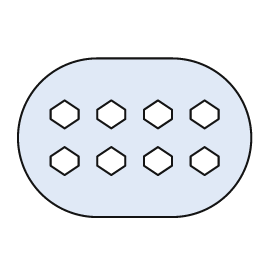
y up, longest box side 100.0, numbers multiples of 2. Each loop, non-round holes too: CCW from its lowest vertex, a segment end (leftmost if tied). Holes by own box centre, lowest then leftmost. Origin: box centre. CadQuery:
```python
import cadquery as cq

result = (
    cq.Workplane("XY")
    .moveTo(-16.0, -34.0)
    .lineTo(16.0, -34.0)
    .threePointArc((50.0, 0.0), (16.0, 34.0))
    .lineTo(-16.0, 34.0)
    .threePointArc((-50.0, 0.0), (-16.0, -34.0))
    .close()
    .moveTo(-30.0, -16.0)
    .lineTo(-24.0, -12.0)
    .lineTo(-24.0, -8.0)
    .lineTo(-30.0, -4.0)
    .lineTo(-36.0, -8.0)
    .lineTo(-36.0, -12.0)
    .close()
    .moveTo(-10.0, -16.0)
    .lineTo(-4.0, -12.0)
    .lineTo(-4.0, -8.0)
    .lineTo(-10.0, -4.0)
    .lineTo(-16.0, -8.0)
    .lineTo(-16.0, -12.0)
    .close()
    .moveTo(10.0, -16.0)
    .lineTo(16.0, -12.0)
    .lineTo(16.0, -8.0)
    .lineTo(10.0, -4.0)
    .lineTo(4.0, -8.0)
    .lineTo(4.0, -12.0)
    .close()
    .moveTo(30.0, -16.0)
    .lineTo(36.0, -12.0)
    .lineTo(36.0, -8.0)
    .lineTo(30.0, -4.0)
    .lineTo(24.0, -8.0)
    .lineTo(24.0, -12.0)
    .close()
    .moveTo(-30.0, 4.0)
    .lineTo(-24.0, 8.0)
    .lineTo(-24.0, 12.0)
    .lineTo(-30.0, 16.0)
    .lineTo(-36.0, 12.0)
    .lineTo(-36.0, 8.0)
    .close()
    .moveTo(-10.0, 4.0)
    .lineTo(-4.0, 8.0)
    .lineTo(-4.0, 12.0)
    .lineTo(-10.0, 16.0)
    .lineTo(-16.0, 12.0)
    .lineTo(-16.0, 8.0)
    .close()
    .moveTo(10.0, 4.0)
    .lineTo(16.0, 8.0)
    .lineTo(16.0, 12.0)
    .lineTo(10.0, 16.0)
    .lineTo(4.0, 12.0)
    .lineTo(4.0, 8.0)
    .close()
    .moveTo(30.0, 4.0)
    .lineTo(36.0, 8.0)
    .lineTo(36.0, 12.0)
    .lineTo(30.0, 16.0)
    .lineTo(24.0, 12.0)
    .lineTo(24.0, 8.0)
    .close()
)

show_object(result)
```